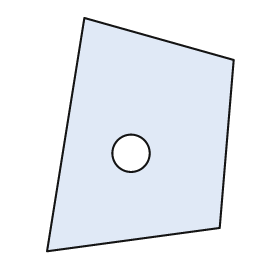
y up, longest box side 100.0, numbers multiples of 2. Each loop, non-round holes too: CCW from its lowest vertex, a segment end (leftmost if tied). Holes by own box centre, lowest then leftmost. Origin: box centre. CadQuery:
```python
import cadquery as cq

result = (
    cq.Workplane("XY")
    .moveTo(-40.0, -50.0)
    .lineTo(34.0, -40.0)
    .lineTo(40.0, 32.0)
    .lineTo(-24.0, 50.0)
    .close()
    .moveTo(-4.0, -8.0)
    .circle(8.0)
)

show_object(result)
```